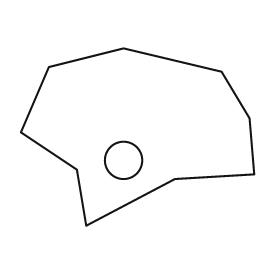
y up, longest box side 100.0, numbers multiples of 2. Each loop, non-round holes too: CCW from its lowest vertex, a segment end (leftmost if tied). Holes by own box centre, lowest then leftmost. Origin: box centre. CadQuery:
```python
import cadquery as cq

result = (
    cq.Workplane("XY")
    .moveTo(-22.0, -38.0)
    .lineTo(16.0, -18.0)
    .lineTo(50.0, -16.0)
    .lineTo(48.0, 8.0)
    .lineTo(36.0, 28.0)
    .lineTo(-6.0, 38.0)
    .lineTo(-38.0, 30.0)
    .lineTo(-50.0, 2.0)
    .lineTo(-26.0, -14.0)
    .close()
    .moveTo(-6.0, -10.0)
    .circle(8.0)
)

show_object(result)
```